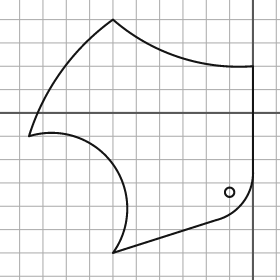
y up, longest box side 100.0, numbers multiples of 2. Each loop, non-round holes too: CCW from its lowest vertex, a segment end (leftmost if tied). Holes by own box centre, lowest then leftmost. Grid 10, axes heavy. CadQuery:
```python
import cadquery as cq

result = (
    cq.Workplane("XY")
    .moveTo(-60.0, -60.0)
    .lineTo(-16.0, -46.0)
    .threePointArc((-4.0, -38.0), (0.0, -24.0))
    .lineTo(0.0, 20.0)
    .threePointArc((-32.0, 24.0), (-60.0, 40.0))
    .threePointArc((-82.0, 18.0), (-96.0, -10.0))
    .threePointArc((-60.0, -22.0), (-60.0, -60.0))
    .close()
    .moveTo(-10.0, -34.0)
    .circle(2.0)
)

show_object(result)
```